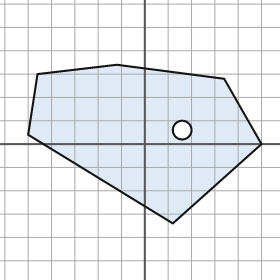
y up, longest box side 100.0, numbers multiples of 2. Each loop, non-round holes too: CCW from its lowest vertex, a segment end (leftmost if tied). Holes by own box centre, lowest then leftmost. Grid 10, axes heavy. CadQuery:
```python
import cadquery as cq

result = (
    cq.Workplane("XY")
    .moveTo(12.0, -34.0)
    .lineTo(50.0, 0.0)
    .lineTo(34.0, 28.0)
    .lineTo(-12.0, 34.0)
    .lineTo(-46.0, 30.0)
    .lineTo(-50.0, 4.0)
    .close()
    .moveTo(16.0, 6.0)
    .circle(4.0)
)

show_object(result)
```